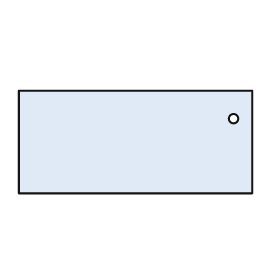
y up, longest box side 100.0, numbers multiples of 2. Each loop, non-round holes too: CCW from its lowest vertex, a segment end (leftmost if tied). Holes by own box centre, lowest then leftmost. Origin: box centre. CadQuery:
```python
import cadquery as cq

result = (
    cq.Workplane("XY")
    .moveTo(-50.0, -22.0)
    .lineTo(50.0, -22.0)
    .lineTo(50.0, 22.0)
    .lineTo(-50.0, 22.0)
    .close()
    .moveTo(42.0, 10.0)
    .circle(2.0)
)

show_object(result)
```